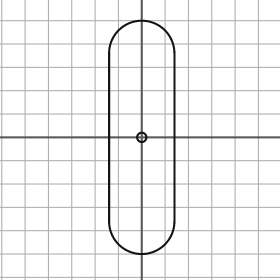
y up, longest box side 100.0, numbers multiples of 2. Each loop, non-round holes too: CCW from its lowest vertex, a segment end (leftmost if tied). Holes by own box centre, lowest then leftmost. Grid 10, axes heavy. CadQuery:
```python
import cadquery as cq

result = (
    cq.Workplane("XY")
    .moveTo(-14.0, -36.0)
    .threePointArc((0.0, -50.0), (14.0, -36.0))
    .lineTo(14.0, 36.0)
    .threePointArc((0.0, 50.0), (-14.0, 36.0))
    .close()
    .moveTo(0.0, 0.0)
    .circle(2.0)
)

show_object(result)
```